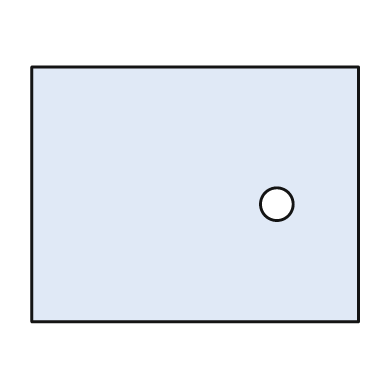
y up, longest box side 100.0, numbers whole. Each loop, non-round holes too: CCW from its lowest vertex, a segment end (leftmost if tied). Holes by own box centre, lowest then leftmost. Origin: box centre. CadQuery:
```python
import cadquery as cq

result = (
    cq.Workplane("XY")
    .moveTo(-50.0, -39.0)
    .lineTo(50.0, -39.0)
    .lineTo(50.0, 39.0)
    .lineTo(-50.0, 39.0)
    .close()
    .moveTo(25.0, -3.0)
    .circle(5.0)
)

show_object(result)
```